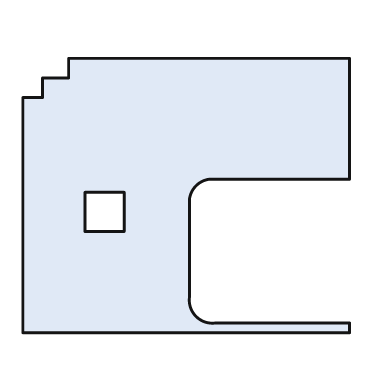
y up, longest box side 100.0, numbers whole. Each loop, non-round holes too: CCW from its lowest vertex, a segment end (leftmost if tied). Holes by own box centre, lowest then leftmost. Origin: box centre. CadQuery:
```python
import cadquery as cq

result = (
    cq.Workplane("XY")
    .moveTo(-50.0, -42.0)
    .lineTo(50.0, -42.0)
    .lineTo(50.0, -39.0)
    .lineTo(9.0, -39.0)
    .threePointArc((3.0, -37.0), (1.0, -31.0))
    .lineTo(1.0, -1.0)
    .threePointArc((3.0, 3.0), (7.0, 5.0))
    .lineTo(50.0, 5.0)
    .lineTo(50.0, 42.0)
    .lineTo(-36.0, 42.0)
    .lineTo(-36.0, 36.0)
    .lineTo(-44.0, 36.0)
    .lineTo(-44.0, 30.0)
    .lineTo(-50.0, 30.0)
    .close()
    .moveTo(-31.0, -11.0)
    .lineTo(-19.0, -11.0)
    .lineTo(-19.0, 1.0)
    .lineTo(-31.0, 1.0)
    .close()
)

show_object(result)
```